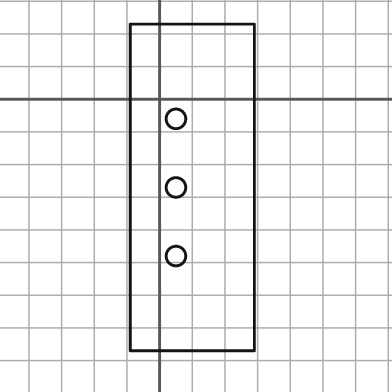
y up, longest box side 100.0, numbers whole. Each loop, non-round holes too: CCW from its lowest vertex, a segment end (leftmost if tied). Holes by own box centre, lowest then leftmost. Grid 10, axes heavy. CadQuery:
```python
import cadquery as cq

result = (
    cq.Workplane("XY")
    .moveTo(-9.0, -77.0)
    .lineTo(29.0, -77.0)
    .lineTo(29.0, 23.0)
    .lineTo(-9.0, 23.0)
    .close()
    .moveTo(5.0, -48.0)
    .circle(3.0)
    .moveTo(5.0, -27.0)
    .circle(3.0)
    .moveTo(5.0, -6.0)
    .circle(3.0)
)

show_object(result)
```